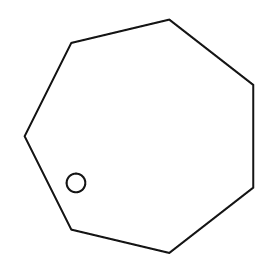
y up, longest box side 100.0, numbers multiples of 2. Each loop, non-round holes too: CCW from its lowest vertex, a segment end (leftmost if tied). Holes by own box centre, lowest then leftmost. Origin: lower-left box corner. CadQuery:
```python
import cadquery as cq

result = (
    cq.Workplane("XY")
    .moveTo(62.0, 0.0)
    .lineTo(98.0, 28.0)
    .lineTo(98.0, 72.0)
    .lineTo(62.0, 100.0)
    .lineTo(20.0, 90.0)
    .lineTo(0.0, 50.0)
    .lineTo(20.0, 10.0)
    .close()
    .moveTo(22.0, 30.0)
    .circle(4.0)
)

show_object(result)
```